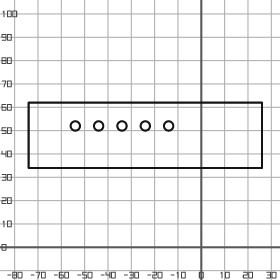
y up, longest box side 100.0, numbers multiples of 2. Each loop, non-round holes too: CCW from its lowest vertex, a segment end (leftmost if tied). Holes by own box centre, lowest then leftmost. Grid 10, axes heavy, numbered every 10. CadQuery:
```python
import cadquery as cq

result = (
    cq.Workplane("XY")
    .moveTo(-74.0, 34.0)
    .lineTo(26.0, 34.0)
    .lineTo(26.0, 62.0)
    .lineTo(-74.0, 62.0)
    .close()
    .moveTo(-54.0, 52.0)
    .circle(2.0)
    .moveTo(-44.0, 52.0)
    .circle(2.0)
    .moveTo(-34.0, 52.0)
    .circle(2.0)
    .moveTo(-24.0, 52.0)
    .circle(2.0)
    .moveTo(-14.0, 52.0)
    .circle(2.0)
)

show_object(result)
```